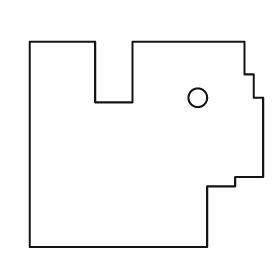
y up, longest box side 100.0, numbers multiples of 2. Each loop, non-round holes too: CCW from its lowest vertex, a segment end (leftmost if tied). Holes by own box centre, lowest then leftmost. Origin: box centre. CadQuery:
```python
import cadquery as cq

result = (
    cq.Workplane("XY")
    .moveTo(-50.0, -44.0)
    .lineTo(26.0, -44.0)
    .lineTo(26.0, -18.0)
    .lineTo(38.0, -18.0)
    .lineTo(38.0, -14.0)
    .lineTo(50.0, -14.0)
    .lineTo(50.0, 20.0)
    .lineTo(46.0, 20.0)
    .lineTo(46.0, 30.0)
    .lineTo(42.0, 30.0)
    .lineTo(42.0, 44.0)
    .lineTo(-6.0, 44.0)
    .lineTo(-6.0, 18.0)
    .lineTo(-22.0, 18.0)
    .lineTo(-22.0, 44.0)
    .lineTo(-50.0, 44.0)
    .close()
    .moveTo(22.0, 20.0)
    .circle(4.0)
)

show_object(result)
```